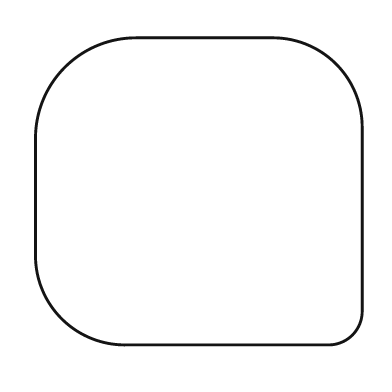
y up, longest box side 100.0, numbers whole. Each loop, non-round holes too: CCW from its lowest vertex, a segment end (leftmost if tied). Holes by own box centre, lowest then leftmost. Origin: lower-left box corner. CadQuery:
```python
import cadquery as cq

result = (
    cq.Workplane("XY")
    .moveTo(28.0, 0.0)
    .lineTo(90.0, 0.0)
    .threePointArc((97.0, 3.0), (100.0, 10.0))
    .lineTo(100.0, 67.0)
    .threePointArc((92.0, 86.0), (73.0, 94.0))
    .lineTo(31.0, 94.0)
    .threePointArc((9.0, 85.0), (0.0, 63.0))
    .lineTo(0.0, 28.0)
    .threePointArc((8.0, 8.0), (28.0, 0.0))
    .close()
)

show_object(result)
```